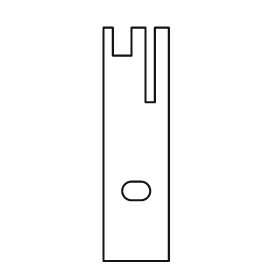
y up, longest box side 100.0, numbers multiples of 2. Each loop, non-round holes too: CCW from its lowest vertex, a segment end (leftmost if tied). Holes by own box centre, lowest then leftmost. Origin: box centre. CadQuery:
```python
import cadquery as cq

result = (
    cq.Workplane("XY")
    .moveTo(-14.0, -50.0)
    .lineTo(14.0, -50.0)
    .lineTo(14.0, 50.0)
    .lineTo(8.0, 50.0)
    .lineTo(8.0, 18.0)
    .lineTo(4.0, 18.0)
    .lineTo(4.0, 50.0)
    .lineTo(-2.0, 50.0)
    .lineTo(-2.0, 38.0)
    .lineTo(-10.0, 38.0)
    .lineTo(-10.0, 50.0)
    .lineTo(-14.0, 50.0)
    .close()
    .moveTo(-2.0, -24.0)
    .lineTo(2.0, -24.0)
    .threePointArc((6.0, -20.0), (2.0, -16.0))
    .lineTo(-2.0, -16.0)
    .threePointArc((-6.0, -20.0), (-2.0, -24.0))
    .close()
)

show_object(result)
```